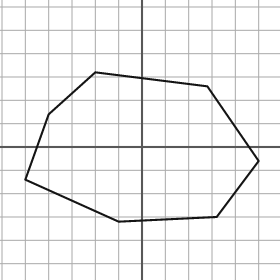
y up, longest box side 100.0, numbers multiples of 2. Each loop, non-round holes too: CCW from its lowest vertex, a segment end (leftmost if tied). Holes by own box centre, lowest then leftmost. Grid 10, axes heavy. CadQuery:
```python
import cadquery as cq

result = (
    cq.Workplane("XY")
    .moveTo(-10.0, -32.0)
    .lineTo(32.0, -30.0)
    .lineTo(50.0, -6.0)
    .lineTo(28.0, 26.0)
    .lineTo(-20.0, 32.0)
    .lineTo(-40.0, 14.0)
    .lineTo(-50.0, -14.0)
    .close()
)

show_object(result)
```